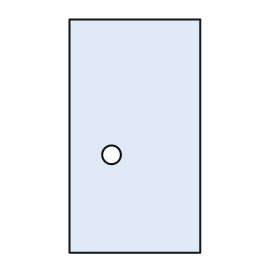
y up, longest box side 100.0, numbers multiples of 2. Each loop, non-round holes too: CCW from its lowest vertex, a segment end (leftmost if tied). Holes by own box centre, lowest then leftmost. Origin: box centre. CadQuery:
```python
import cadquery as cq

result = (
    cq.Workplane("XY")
    .moveTo(-28.0, -50.0)
    .lineTo(28.0, -50.0)
    .lineTo(28.0, 50.0)
    .lineTo(-28.0, 50.0)
    .close()
    .moveTo(-10.0, -8.0)
    .circle(4.0)
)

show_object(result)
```